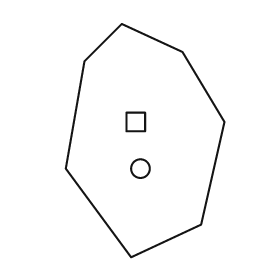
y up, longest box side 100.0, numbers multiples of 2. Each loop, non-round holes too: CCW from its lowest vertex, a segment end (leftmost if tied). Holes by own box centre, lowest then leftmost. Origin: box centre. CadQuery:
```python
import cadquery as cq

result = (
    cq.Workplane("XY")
    .moveTo(-6.0, -50.0)
    .lineTo(24.0, -36.0)
    .lineTo(34.0, 8.0)
    .lineTo(16.0, 38.0)
    .lineTo(-10.0, 50.0)
    .lineTo(-26.0, 34.0)
    .lineTo(-34.0, -12.0)
    .close()
    .moveTo(-2.0, -12.0)
    .circle(4.0)
    .moveTo(-8.0, 4.0)
    .lineTo(0.0, 4.0)
    .lineTo(0.0, 12.0)
    .lineTo(-8.0, 12.0)
    .close()
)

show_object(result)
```